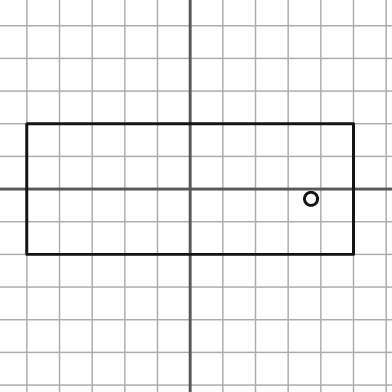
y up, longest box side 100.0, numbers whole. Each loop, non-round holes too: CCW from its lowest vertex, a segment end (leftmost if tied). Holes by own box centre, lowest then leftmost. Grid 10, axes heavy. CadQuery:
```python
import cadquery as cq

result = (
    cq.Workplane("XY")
    .moveTo(-50.0, -20.0)
    .lineTo(50.0, -20.0)
    .lineTo(50.0, 20.0)
    .lineTo(-50.0, 20.0)
    .close()
    .moveTo(37.0, -3.0)
    .circle(2.0)
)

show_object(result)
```